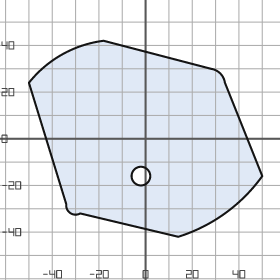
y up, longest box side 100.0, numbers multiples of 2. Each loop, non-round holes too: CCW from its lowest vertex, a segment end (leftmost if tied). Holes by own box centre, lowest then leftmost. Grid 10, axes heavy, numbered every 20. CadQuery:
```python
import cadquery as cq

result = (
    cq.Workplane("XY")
    .moveTo(14.0, -42.0)
    .threePointArc((34.0, -32.0), (50.0, -16.0))
    .lineTo(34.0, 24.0)
    .threePointArc((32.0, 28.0), (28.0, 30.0))
    .lineTo(-18.0, 42.0)
    .threePointArc((-36.0, 36.0), (-50.0, 24.0))
    .lineTo(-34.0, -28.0)
    .threePointArc((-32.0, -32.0), (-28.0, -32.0))
    .close()
    .moveTo(-2.0, -16.0)
    .circle(4.0)
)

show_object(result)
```